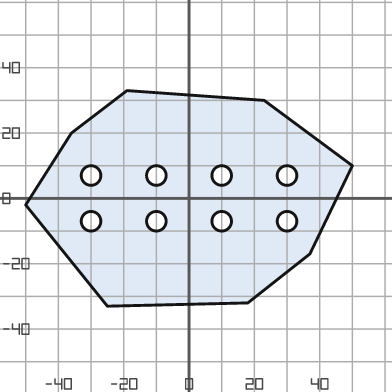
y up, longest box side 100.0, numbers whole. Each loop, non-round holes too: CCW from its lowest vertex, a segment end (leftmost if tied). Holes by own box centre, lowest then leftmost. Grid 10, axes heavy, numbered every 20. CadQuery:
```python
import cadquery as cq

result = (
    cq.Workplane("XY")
    .moveTo(-25.0, -33.0)
    .lineTo(18.0, -32.0)
    .lineTo(37.0, -17.0)
    .lineTo(50.0, 10.0)
    .lineTo(23.0, 30.0)
    .lineTo(-19.0, 33.0)
    .lineTo(-36.0, 20.0)
    .lineTo(-50.0, -2.0)
    .close()
    .moveTo(-30.0, -7.0)
    .circle(3.0)
    .moveTo(-10.0, -7.0)
    .circle(3.0)
    .moveTo(10.0, -7.0)
    .circle(3.0)
    .moveTo(30.0, -7.0)
    .circle(3.0)
    .moveTo(-30.0, 7.0)
    .circle(3.0)
    .moveTo(-10.0, 7.0)
    .circle(3.0)
    .moveTo(10.0, 7.0)
    .circle(3.0)
    .moveTo(30.0, 7.0)
    .circle(3.0)
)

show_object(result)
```